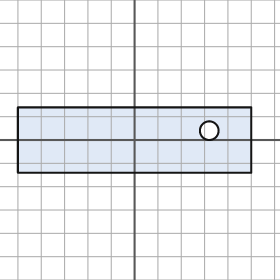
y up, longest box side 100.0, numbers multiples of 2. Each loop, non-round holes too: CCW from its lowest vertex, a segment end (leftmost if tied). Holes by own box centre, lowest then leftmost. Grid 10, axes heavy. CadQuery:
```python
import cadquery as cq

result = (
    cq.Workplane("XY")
    .moveTo(-50.0, -14.0)
    .lineTo(50.0, -14.0)
    .lineTo(50.0, 14.0)
    .lineTo(-50.0, 14.0)
    .close()
    .moveTo(32.0, 4.0)
    .circle(4.0)
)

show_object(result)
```